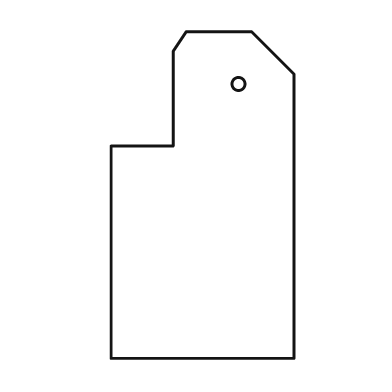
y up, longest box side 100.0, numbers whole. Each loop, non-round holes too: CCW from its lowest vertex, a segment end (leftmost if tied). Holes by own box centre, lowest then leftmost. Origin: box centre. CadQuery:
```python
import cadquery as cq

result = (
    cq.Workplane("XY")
    .moveTo(-28.0, -50.0)
    .lineTo(28.0, -50.0)
    .lineTo(28.0, 37.0)
    .lineTo(15.0, 50.0)
    .lineTo(-5.0, 50.0)
    .lineTo(-9.0, 44.0)
    .lineTo(-9.0, 15.0)
    .lineTo(-28.0, 15.0)
    .close()
    .moveTo(11.0, 34.0)
    .circle(2.0)
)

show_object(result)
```